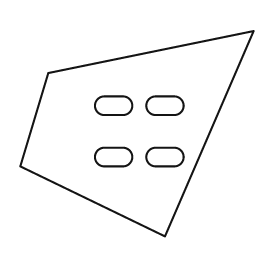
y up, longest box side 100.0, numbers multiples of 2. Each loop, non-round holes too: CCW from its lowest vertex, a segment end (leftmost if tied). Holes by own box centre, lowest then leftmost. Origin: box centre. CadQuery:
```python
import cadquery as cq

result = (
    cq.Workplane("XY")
    .moveTo(12.0, -44.0)
    .lineTo(50.0, 44.0)
    .lineTo(-38.0, 26.0)
    .lineTo(-50.0, -14.0)
    .close()
    .moveTo(-14.0, -14.0)
    .lineTo(-6.0, -14.0)
    .threePointArc((-2.0, -10.0), (-6.0, -6.0))
    .lineTo(-14.0, -6.0)
    .threePointArc((-18.0, -10.0), (-14.0, -14.0))
    .close()
    .moveTo(8.0, -14.0)
    .lineTo(16.0, -14.0)
    .threePointArc((20.0, -10.0), (16.0, -6.0))
    .lineTo(8.0, -6.0)
    .threePointArc((4.0, -10.0), (8.0, -14.0))
    .close()
    .moveTo(-14.0, 8.0)
    .lineTo(-6.0, 8.0)
    .threePointArc((-2.0, 12.0), (-6.0, 16.0))
    .lineTo(-14.0, 16.0)
    .threePointArc((-18.0, 12.0), (-14.0, 8.0))
    .close()
    .moveTo(8.0, 8.0)
    .lineTo(16.0, 8.0)
    .threePointArc((20.0, 12.0), (16.0, 16.0))
    .lineTo(8.0, 16.0)
    .threePointArc((4.0, 12.0), (8.0, 8.0))
    .close()
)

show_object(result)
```